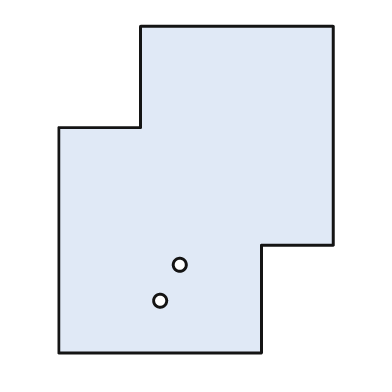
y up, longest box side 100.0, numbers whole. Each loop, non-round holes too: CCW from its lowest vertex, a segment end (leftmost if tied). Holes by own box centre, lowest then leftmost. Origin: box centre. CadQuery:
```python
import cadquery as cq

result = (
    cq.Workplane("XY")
    .moveTo(-42.0, -50.0)
    .lineTo(20.0, -50.0)
    .lineTo(20.0, -17.0)
    .lineTo(42.0, -17.0)
    .lineTo(42.0, 50.0)
    .lineTo(-17.0, 50.0)
    .lineTo(-17.0, 19.0)
    .lineTo(-42.0, 19.0)
    .close()
    .moveTo(-11.0, -34.0)
    .circle(2.0)
    .moveTo(-5.0, -23.0)
    .circle(2.0)
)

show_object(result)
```